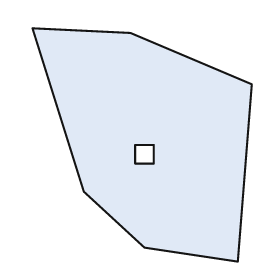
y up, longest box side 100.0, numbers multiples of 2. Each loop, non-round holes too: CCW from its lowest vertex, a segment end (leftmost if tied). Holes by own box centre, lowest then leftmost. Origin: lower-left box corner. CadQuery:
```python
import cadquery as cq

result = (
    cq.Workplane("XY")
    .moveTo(88.0, 0.0)
    .lineTo(94.0, 76.0)
    .lineTo(42.0, 98.0)
    .lineTo(0.0, 100.0)
    .lineTo(22.0, 30.0)
    .lineTo(48.0, 6.0)
    .close()
    .moveTo(44.0, 42.0)
    .lineTo(52.0, 42.0)
    .lineTo(52.0, 50.0)
    .lineTo(44.0, 50.0)
    .close()
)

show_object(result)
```